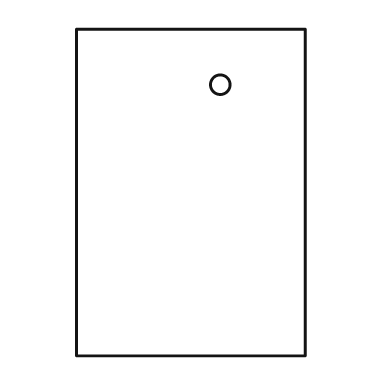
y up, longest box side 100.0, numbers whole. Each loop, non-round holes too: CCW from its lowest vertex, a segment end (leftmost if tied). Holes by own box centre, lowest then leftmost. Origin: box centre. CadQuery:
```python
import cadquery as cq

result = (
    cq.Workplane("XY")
    .moveTo(-35.0, -50.0)
    .lineTo(35.0, -50.0)
    .lineTo(35.0, 50.0)
    .lineTo(-35.0, 50.0)
    .close()
    .moveTo(9.0, 33.0)
    .circle(3.0)
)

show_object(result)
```